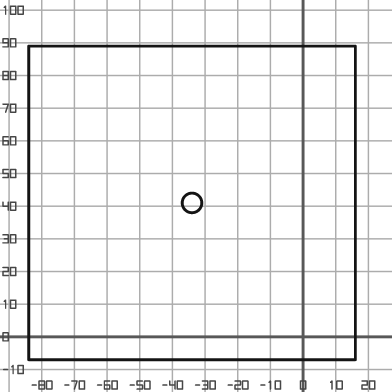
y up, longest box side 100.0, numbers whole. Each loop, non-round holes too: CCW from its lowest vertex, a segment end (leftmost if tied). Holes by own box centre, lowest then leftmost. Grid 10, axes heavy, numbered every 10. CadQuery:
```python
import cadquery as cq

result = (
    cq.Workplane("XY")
    .moveTo(-84.0, -7.0)
    .lineTo(16.0, -7.0)
    .lineTo(16.0, 89.0)
    .lineTo(-84.0, 89.0)
    .close()
    .moveTo(-34.0, 41.0)
    .circle(3.0)
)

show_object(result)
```